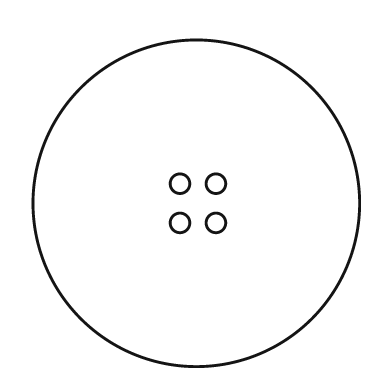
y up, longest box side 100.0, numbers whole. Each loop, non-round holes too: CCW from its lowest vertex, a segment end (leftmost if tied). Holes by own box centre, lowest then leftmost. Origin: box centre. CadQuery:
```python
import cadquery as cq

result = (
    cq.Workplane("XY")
    .moveTo(0.0, 0.0)
    .circle(50.0)
    .moveTo(-5.0, -6.0)
    .circle(3.0)
    .moveTo(6.0, -6.0)
    .circle(3.0)
    .moveTo(-5.0, 6.0)
    .circle(3.0)
    .moveTo(6.0, 6.0)
    .circle(3.0)
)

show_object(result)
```